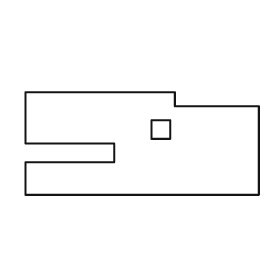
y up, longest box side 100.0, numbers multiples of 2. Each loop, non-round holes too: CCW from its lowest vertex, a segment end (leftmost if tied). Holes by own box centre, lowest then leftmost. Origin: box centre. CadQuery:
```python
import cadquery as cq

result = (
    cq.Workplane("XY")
    .moveTo(-50.0, -22.0)
    .lineTo(50.0, -22.0)
    .lineTo(50.0, 16.0)
    .lineTo(14.0, 16.0)
    .lineTo(14.0, 22.0)
    .lineTo(-50.0, 22.0)
    .lineTo(-50.0, 0.0)
    .lineTo(-12.0, 0.0)
    .lineTo(-12.0, -8.0)
    .lineTo(-50.0, -8.0)
    .close()
    .moveTo(4.0, 2.0)
    .lineTo(12.0, 2.0)
    .lineTo(12.0, 10.0)
    .lineTo(4.0, 10.0)
    .close()
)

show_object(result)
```